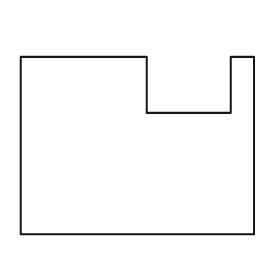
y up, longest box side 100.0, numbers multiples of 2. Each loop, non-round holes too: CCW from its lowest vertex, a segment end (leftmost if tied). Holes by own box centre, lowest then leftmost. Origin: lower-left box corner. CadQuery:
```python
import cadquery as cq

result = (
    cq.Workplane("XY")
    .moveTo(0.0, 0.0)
    .lineTo(100.0, 0.0)
    .lineTo(100.0, 76.0)
    .lineTo(90.0, 76.0)
    .lineTo(90.0, 52.0)
    .lineTo(54.0, 52.0)
    .lineTo(54.0, 76.0)
    .lineTo(0.0, 76.0)
    .close()
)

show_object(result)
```